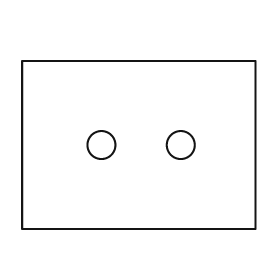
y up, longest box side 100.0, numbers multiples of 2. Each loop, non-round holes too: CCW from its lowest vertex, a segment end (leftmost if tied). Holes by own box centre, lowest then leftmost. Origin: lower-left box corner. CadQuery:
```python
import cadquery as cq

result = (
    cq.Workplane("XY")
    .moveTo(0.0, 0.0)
    .lineTo(100.0, 0.0)
    .lineTo(100.0, 72.0)
    .lineTo(0.0, 72.0)
    .close()
    .moveTo(34.0, 36.0)
    .circle(6.0)
    .moveTo(68.0, 36.0)
    .circle(6.0)
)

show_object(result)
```